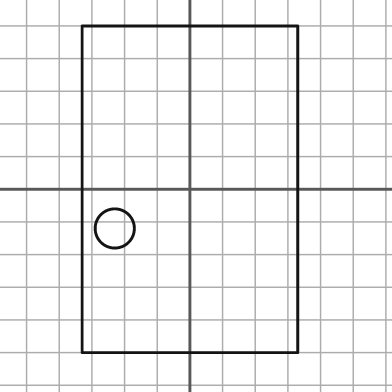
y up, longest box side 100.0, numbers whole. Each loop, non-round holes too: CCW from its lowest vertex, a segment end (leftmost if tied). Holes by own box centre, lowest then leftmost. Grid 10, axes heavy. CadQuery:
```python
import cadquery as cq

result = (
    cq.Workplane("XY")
    .moveTo(-33.0, -50.0)
    .lineTo(33.0, -50.0)
    .lineTo(33.0, 50.0)
    .lineTo(-33.0, 50.0)
    .close()
    .moveTo(-23.0, -12.0)
    .circle(6.0)
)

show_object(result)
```